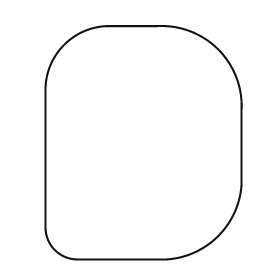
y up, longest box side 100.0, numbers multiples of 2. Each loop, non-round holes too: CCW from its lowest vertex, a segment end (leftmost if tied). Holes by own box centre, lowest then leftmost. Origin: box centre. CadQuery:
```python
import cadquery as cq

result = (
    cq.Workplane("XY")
    .moveTo(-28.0, -50.0)
    .lineTo(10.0, -50.0)
    .threePointArc((32.0, -40.0), (42.0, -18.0))
    .lineTo(42.0, 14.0)
    .threePointArc((32.0, 40.0), (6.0, 50.0))
    .lineTo(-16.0, 50.0)
    .threePointArc((-34.0, 42.0), (-42.0, 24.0))
    .lineTo(-42.0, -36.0)
    .threePointArc((-38.0, -46.0), (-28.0, -50.0))
    .close()
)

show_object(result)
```